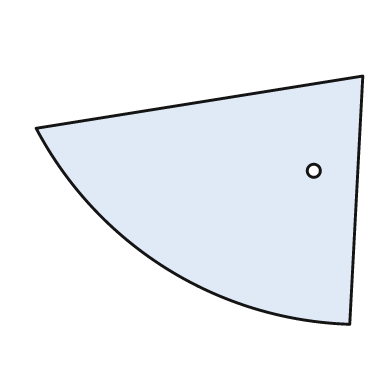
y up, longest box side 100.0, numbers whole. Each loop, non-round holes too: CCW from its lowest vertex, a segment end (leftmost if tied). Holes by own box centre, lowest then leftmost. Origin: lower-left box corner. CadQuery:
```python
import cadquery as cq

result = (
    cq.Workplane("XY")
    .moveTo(96.0, 0.0)
    .lineTo(100.0, 76.0)
    .lineTo(0.0, 60.0)
    .threePointArc((40.0, 17.0), (96.0, 0.0))
    .close()
    .moveTo(85.0, 47.0)
    .circle(2.0)
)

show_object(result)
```